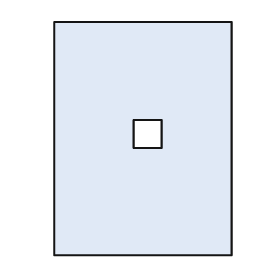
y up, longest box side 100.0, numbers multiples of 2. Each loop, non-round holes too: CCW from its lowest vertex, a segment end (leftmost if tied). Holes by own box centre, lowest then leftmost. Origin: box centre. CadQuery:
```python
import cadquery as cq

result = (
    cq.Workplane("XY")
    .moveTo(-38.0, -50.0)
    .lineTo(38.0, -50.0)
    .lineTo(38.0, 50.0)
    .lineTo(-38.0, 50.0)
    .close()
    .moveTo(-4.0, -4.0)
    .lineTo(8.0, -4.0)
    .lineTo(8.0, 8.0)
    .lineTo(-4.0, 8.0)
    .close()
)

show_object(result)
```